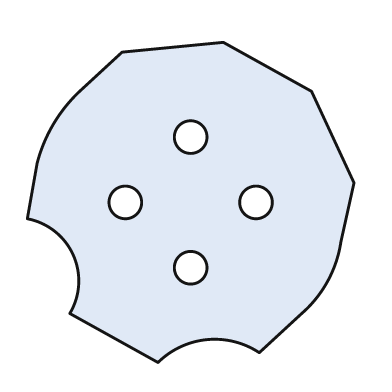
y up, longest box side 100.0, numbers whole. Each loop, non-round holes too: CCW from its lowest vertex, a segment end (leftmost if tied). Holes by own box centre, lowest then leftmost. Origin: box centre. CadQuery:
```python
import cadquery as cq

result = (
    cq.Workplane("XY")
    .moveTo(-10.0, -49.0)
    .threePointArc((5.0, -42.0), (21.0, -46.0))
    .lineTo(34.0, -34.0)
    .threePointArc((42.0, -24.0), (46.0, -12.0))
    .lineTo(50.0, 6.0)
    .lineTo(37.0, 34.0)
    .lineTo(10.0, 49.0)
    .lineTo(-21.0, 46.0)
    .lineTo(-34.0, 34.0)
    .threePointArc((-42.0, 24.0), (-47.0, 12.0))
    .lineTo(-50.0, -5.0)
    .threePointArc((-36.0, -16.0), (-37.0, -34.0))
    .close()
    .moveTo(0.0, -20.0)
    .circle(5.0)
    .moveTo(-20.0, 0.0)
    .circle(5.0)
    .moveTo(20.0, 0.0)
    .circle(5.0)
    .moveTo(0.0, 20.0)
    .circle(5.0)
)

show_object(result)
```